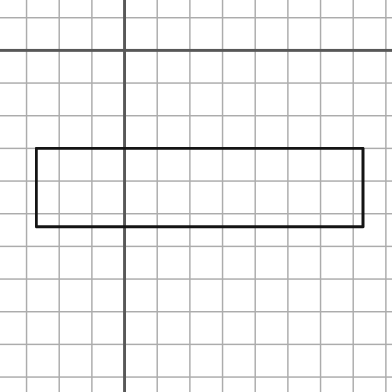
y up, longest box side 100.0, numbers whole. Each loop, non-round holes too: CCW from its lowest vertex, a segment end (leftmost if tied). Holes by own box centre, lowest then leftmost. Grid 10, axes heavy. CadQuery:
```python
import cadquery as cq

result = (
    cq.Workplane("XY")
    .moveTo(-27.0, -54.0)
    .lineTo(73.0, -54.0)
    .lineTo(73.0, -30.0)
    .lineTo(-27.0, -30.0)
    .close()
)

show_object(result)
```